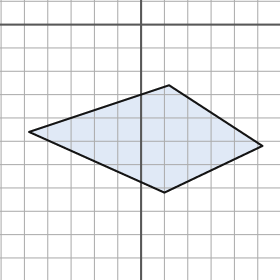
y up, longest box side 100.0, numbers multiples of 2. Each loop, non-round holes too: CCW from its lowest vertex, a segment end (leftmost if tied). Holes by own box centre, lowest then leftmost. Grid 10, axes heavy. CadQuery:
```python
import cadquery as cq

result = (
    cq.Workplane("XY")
    .moveTo(10.0, -72.0)
    .lineTo(52.0, -52.0)
    .lineTo(12.0, -26.0)
    .lineTo(-48.0, -46.0)
    .close()
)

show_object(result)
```